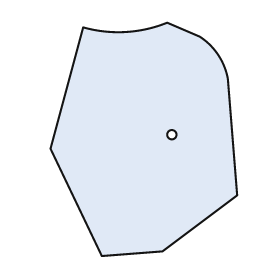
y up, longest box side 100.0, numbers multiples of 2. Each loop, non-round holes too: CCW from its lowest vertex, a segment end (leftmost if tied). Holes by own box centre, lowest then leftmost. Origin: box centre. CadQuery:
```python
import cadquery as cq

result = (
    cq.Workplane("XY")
    .moveTo(-18.0, -50.0)
    .lineTo(8.0, -48.0)
    .lineTo(40.0, -24.0)
    .lineTo(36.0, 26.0)
    .threePointArc((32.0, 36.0), (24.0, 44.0))
    .lineTo(10.0, 50.0)
    .threePointArc((-8.0, 46.0), (-26.0, 48.0))
    .lineTo(-40.0, -4.0)
    .close()
    .moveTo(12.0, 2.0)
    .circle(2.0)
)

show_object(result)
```